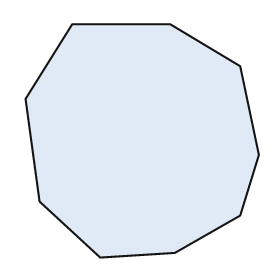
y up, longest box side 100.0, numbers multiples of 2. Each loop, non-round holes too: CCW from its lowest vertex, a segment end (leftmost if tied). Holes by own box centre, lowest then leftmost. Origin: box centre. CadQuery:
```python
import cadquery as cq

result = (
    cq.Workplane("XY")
    .moveTo(-18.0, -50.0)
    .lineTo(14.0, -48.0)
    .lineTo(42.0, -32.0)
    .lineTo(50.0, -6.0)
    .lineTo(42.0, 32.0)
    .lineTo(12.0, 50.0)
    .lineTo(-30.0, 50.0)
    .lineTo(-50.0, 18.0)
    .lineTo(-44.0, -26.0)
    .close()
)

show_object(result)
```